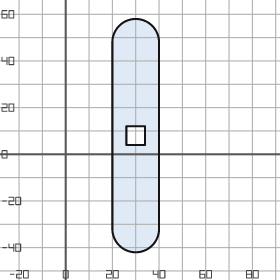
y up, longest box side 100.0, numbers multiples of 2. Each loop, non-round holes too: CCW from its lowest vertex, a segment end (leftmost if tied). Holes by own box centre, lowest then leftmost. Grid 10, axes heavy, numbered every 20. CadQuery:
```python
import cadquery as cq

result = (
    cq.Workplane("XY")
    .moveTo(20.0, -32.0)
    .threePointArc((30.0, -42.0), (40.0, -32.0))
    .lineTo(40.0, 48.0)
    .threePointArc((30.0, 58.0), (20.0, 48.0))
    .close()
    .moveTo(26.0, 4.0)
    .lineTo(34.0, 4.0)
    .lineTo(34.0, 12.0)
    .lineTo(26.0, 12.0)
    .close()
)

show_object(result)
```